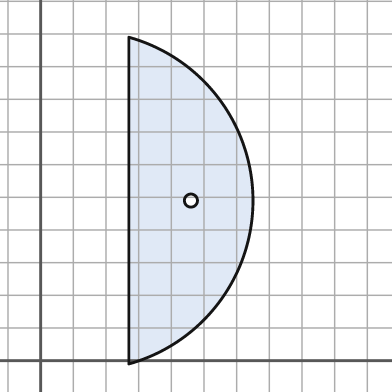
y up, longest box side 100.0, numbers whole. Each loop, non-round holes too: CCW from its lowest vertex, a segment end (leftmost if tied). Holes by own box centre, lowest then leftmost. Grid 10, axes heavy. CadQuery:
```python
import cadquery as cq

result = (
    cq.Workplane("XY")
    .moveTo(27.0, -1.0)
    .threePointArc((65.0, 49.0), (27.0, 99.0))
    .close()
    .moveTo(46.0, 49.0)
    .circle(2.0)
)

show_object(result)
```